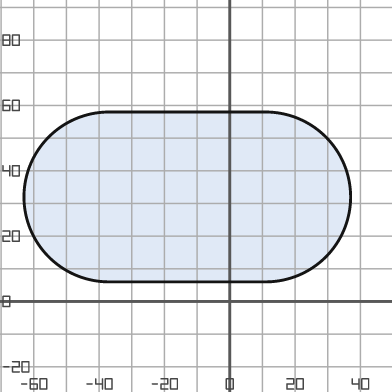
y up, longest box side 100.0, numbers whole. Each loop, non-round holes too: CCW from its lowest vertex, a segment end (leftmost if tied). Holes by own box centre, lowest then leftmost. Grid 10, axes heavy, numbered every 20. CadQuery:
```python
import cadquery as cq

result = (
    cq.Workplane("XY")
    .moveTo(-37.0, 6.0)
    .lineTo(11.0, 6.0)
    .threePointArc((37.0, 32.0), (11.0, 58.0))
    .lineTo(-37.0, 58.0)
    .threePointArc((-63.0, 32.0), (-37.0, 6.0))
    .close()
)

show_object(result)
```